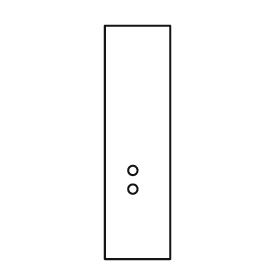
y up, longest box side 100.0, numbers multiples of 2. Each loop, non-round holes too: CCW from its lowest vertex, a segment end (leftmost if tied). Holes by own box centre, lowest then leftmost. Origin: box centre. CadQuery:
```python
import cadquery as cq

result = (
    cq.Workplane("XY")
    .moveTo(-14.0, -50.0)
    .lineTo(14.0, -50.0)
    .lineTo(14.0, 50.0)
    .lineTo(-14.0, 50.0)
    .close()
    .moveTo(-2.0, -20.0)
    .circle(2.0)
    .moveTo(-2.0, -12.0)
    .circle(2.0)
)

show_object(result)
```